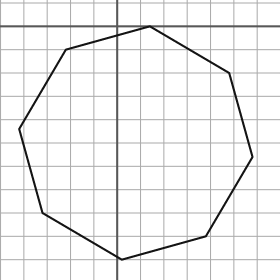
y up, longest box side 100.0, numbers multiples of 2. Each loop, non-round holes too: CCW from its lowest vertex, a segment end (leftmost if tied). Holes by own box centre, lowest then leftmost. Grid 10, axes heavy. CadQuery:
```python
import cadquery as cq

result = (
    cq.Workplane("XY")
    .moveTo(2.0, -100.0)
    .lineTo(38.0, -90.0)
    .lineTo(58.0, -56.0)
    .lineTo(48.0, -20.0)
    .lineTo(14.0, 0.0)
    .lineTo(-22.0, -10.0)
    .lineTo(-42.0, -44.0)
    .lineTo(-32.0, -80.0)
    .close()
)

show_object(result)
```